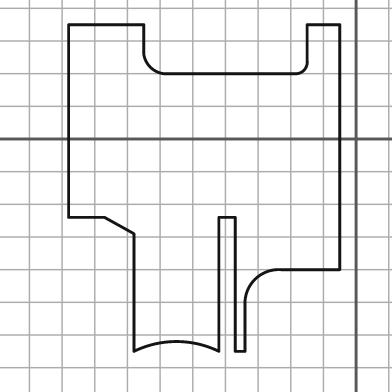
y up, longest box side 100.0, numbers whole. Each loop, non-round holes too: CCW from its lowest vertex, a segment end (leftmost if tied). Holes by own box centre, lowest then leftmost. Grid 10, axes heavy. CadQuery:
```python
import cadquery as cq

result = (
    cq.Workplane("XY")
    .moveTo(-68.0, -65.0)
    .threePointArc((-55.0, -62.0), (-42.0, -65.0))
    .lineTo(-42.0, -24.0)
    .lineTo(-37.0, -24.0)
    .lineTo(-37.0, -65.0)
    .lineTo(-34.0, -65.0)
    .lineTo(-34.0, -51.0)
    .threePointArc((-31.0, -43.0), (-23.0, -40.0))
    .lineTo(-5.0, -40.0)
    .lineTo(-5.0, 35.0)
    .lineTo(-15.0, 35.0)
    .lineTo(-15.0, 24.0)
    .threePointArc((-16.0, 21.0), (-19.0, 20.0))
    .lineTo(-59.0, 20.0)
    .threePointArc((-63.0, 22.0), (-65.0, 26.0))
    .lineTo(-65.0, 35.0)
    .lineTo(-88.0, 35.0)
    .lineTo(-88.0, -24.0)
    .lineTo(-77.0, -24.0)
    .lineTo(-68.0, -29.0)
    .close()
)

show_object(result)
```